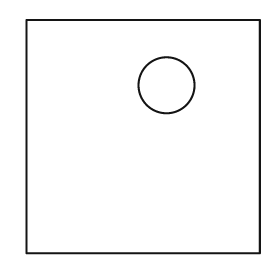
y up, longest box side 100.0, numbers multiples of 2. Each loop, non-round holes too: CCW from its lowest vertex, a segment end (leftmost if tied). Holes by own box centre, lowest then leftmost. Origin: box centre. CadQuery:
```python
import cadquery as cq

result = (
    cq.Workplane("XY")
    .moveTo(-50.0, -50.0)
    .lineTo(50.0, -50.0)
    .lineTo(50.0, 50.0)
    .lineTo(-50.0, 50.0)
    .close()
    .moveTo(10.0, 22.0)
    .circle(12.0)
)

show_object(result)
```